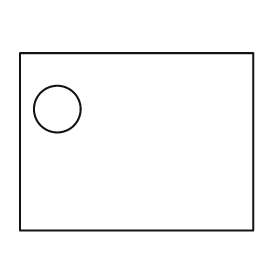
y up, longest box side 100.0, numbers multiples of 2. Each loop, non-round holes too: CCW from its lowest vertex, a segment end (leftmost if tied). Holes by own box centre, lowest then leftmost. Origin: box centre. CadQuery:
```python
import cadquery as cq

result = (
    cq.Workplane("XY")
    .moveTo(-50.0, -38.0)
    .lineTo(50.0, -38.0)
    .lineTo(50.0, 38.0)
    .lineTo(-50.0, 38.0)
    .close()
    .moveTo(-34.0, 14.0)
    .circle(10.0)
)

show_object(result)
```